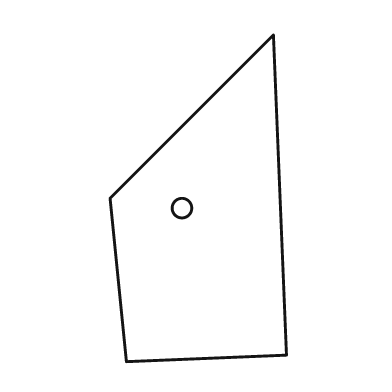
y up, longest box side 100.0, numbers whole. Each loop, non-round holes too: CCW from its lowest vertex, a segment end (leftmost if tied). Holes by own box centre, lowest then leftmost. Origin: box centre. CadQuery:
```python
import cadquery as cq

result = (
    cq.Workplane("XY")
    .moveTo(-22.0, -50.0)
    .lineTo(27.0, -48.0)
    .lineTo(23.0, 50.0)
    .lineTo(-27.0, 0.0)
    .close()
    .moveTo(-5.0, -3.0)
    .circle(3.0)
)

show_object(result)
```